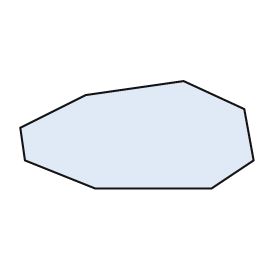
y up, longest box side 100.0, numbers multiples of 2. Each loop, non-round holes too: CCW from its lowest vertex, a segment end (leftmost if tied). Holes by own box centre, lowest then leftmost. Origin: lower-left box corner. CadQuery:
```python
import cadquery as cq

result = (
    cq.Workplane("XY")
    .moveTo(32.0, 0.0)
    .lineTo(82.0, 0.0)
    .lineTo(100.0, 12.0)
    .lineTo(96.0, 34.0)
    .lineTo(70.0, 46.0)
    .lineTo(28.0, 40.0)
    .lineTo(0.0, 26.0)
    .lineTo(2.0, 12.0)
    .close()
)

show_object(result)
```